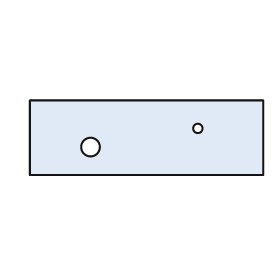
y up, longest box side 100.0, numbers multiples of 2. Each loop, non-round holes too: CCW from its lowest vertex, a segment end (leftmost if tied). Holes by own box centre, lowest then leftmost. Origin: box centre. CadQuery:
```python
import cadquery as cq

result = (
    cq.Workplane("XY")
    .moveTo(-50.0, -16.0)
    .lineTo(50.0, -16.0)
    .lineTo(50.0, 16.0)
    .lineTo(-50.0, 16.0)
    .close()
    .moveTo(-24.0, -4.0)
    .circle(4.0)
    .moveTo(22.0, 4.0)
    .circle(2.0)
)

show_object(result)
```